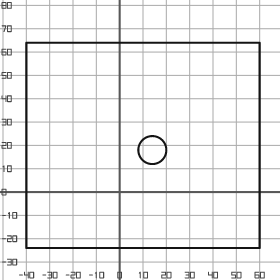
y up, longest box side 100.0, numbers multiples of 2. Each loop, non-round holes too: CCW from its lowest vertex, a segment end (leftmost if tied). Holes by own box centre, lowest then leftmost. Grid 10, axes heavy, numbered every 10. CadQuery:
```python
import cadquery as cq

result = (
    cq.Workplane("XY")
    .moveTo(-40.0, -24.0)
    .lineTo(60.0, -24.0)
    .lineTo(60.0, 64.0)
    .lineTo(-40.0, 64.0)
    .close()
    .moveTo(14.0, 18.0)
    .circle(6.0)
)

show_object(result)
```